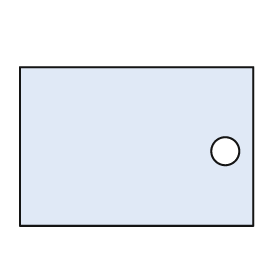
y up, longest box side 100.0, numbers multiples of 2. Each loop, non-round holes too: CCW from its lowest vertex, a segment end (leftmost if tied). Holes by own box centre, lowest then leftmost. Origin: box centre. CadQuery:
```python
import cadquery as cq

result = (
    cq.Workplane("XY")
    .moveTo(-50.0, -34.0)
    .lineTo(50.0, -34.0)
    .lineTo(50.0, 34.0)
    .lineTo(-50.0, 34.0)
    .close()
    .moveTo(38.0, -2.0)
    .circle(6.0)
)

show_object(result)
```